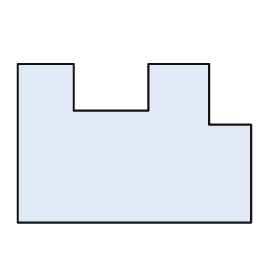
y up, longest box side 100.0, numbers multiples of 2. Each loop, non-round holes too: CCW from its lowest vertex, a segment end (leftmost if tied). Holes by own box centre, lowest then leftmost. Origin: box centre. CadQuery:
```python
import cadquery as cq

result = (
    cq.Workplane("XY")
    .moveTo(-50.0, -34.0)
    .lineTo(50.0, -34.0)
    .lineTo(50.0, 8.0)
    .lineTo(32.0, 8.0)
    .lineTo(32.0, 34.0)
    .lineTo(6.0, 34.0)
    .lineTo(6.0, 14.0)
    .lineTo(-26.0, 14.0)
    .lineTo(-26.0, 34.0)
    .lineTo(-50.0, 34.0)
    .close()
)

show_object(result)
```